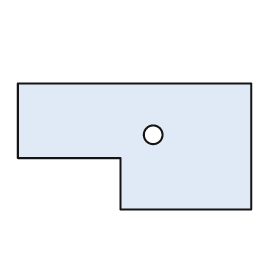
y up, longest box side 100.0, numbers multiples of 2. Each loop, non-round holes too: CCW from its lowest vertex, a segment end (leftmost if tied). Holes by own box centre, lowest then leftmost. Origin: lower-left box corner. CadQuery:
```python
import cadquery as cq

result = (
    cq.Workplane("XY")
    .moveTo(44.0, 0.0)
    .lineTo(100.0, 0.0)
    .lineTo(100.0, 54.0)
    .lineTo(0.0, 54.0)
    .lineTo(0.0, 22.0)
    .lineTo(44.0, 22.0)
    .close()
    .moveTo(58.0, 32.0)
    .circle(4.0)
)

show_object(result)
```